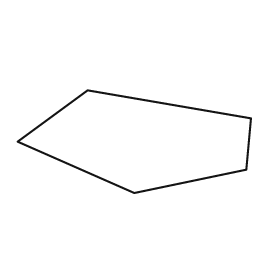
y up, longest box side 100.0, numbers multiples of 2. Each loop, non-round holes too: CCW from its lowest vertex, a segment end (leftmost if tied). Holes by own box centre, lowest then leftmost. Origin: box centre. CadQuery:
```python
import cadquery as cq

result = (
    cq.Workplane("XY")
    .moveTo(0.0, -22.0)
    .lineTo(48.0, -12.0)
    .lineTo(50.0, 10.0)
    .lineTo(-20.0, 22.0)
    .lineTo(-50.0, 0.0)
    .close()
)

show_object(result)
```